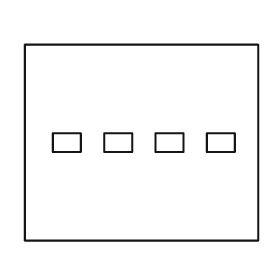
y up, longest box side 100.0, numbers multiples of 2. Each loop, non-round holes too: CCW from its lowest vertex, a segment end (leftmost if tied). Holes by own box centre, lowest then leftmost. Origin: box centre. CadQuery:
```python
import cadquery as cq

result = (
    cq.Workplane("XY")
    .moveTo(-50.0, -42.0)
    .lineTo(50.0, -42.0)
    .lineTo(50.0, 42.0)
    .lineTo(-50.0, 42.0)
    .close()
    .moveTo(-38.0, -4.0)
    .lineTo(-26.0, -4.0)
    .lineTo(-26.0, 4.0)
    .lineTo(-38.0, 4.0)
    .close()
    .moveTo(-16.0, -4.0)
    .lineTo(-4.0, -4.0)
    .lineTo(-4.0, 4.0)
    .lineTo(-16.0, 4.0)
    .close()
    .moveTo(6.0, -4.0)
    .lineTo(18.0, -4.0)
    .lineTo(18.0, 4.0)
    .lineTo(6.0, 4.0)
    .close()
    .moveTo(28.0, -4.0)
    .lineTo(40.0, -4.0)
    .lineTo(40.0, 4.0)
    .lineTo(28.0, 4.0)
    .close()
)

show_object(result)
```